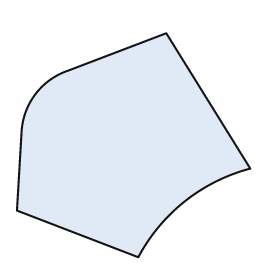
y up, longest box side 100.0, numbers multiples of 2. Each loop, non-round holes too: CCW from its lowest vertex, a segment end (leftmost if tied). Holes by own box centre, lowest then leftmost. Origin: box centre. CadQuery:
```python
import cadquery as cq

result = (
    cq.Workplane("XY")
    .moveTo(2.0, -48.0)
    .threePointArc((22.0, -24.0), (50.0, -10.0))
    .lineTo(14.0, 48.0)
    .lineTo(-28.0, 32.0)
    .threePointArc((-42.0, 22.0), (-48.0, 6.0))
    .lineTo(-50.0, -28.0)
    .close()
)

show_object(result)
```